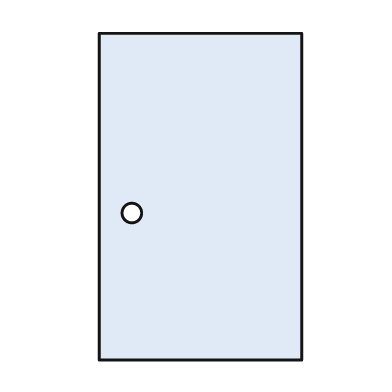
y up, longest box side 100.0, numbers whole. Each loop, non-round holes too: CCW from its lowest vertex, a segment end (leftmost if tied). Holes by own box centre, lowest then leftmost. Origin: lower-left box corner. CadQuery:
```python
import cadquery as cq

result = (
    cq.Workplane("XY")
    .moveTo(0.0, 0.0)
    .lineTo(62.0, 0.0)
    .lineTo(62.0, 100.0)
    .lineTo(0.0, 100.0)
    .close()
    .moveTo(10.0, 45.0)
    .circle(3.0)
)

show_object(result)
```